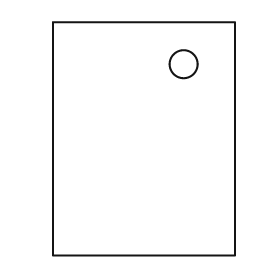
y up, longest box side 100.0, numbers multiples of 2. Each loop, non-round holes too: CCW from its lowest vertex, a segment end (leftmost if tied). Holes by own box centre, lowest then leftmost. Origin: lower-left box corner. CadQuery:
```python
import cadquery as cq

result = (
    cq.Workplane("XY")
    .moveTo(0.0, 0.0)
    .lineTo(78.0, 0.0)
    .lineTo(78.0, 100.0)
    .lineTo(0.0, 100.0)
    .close()
    .moveTo(56.0, 82.0)
    .circle(6.0)
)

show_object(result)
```